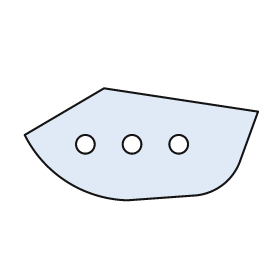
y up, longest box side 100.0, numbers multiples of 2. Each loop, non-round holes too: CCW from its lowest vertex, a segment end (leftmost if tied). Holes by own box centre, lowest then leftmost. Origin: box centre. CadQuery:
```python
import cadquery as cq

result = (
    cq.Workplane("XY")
    .moveTo(-6.0, -24.0)
    .lineTo(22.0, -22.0)
    .threePointArc((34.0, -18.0), (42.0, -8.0))
    .lineTo(50.0, 14.0)
    .lineTo(-16.0, 24.0)
    .lineTo(-50.0, 4.0)
    .threePointArc((-32.0, -16.0), (-6.0, -24.0))
    .close()
    .moveTo(-24.0, 0.0)
    .circle(4.0)
    .moveTo(-4.0, 0.0)
    .circle(4.0)
    .moveTo(16.0, 0.0)
    .circle(4.0)
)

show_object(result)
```